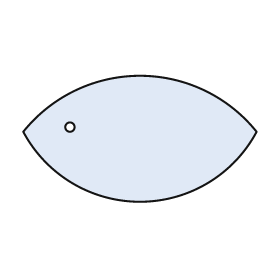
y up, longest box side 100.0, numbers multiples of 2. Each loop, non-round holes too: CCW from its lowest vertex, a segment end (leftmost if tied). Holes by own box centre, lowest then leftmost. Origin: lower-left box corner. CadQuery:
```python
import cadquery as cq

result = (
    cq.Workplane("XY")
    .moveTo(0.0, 30.0)
    .threePointArc((50.0, 0.0), (100.0, 30.0))
    .threePointArc((50.0, 54.0), (0.0, 30.0))
    .close()
    .moveTo(20.0, 32.0)
    .circle(2.0)
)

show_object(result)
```